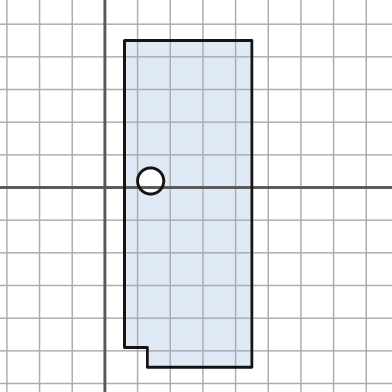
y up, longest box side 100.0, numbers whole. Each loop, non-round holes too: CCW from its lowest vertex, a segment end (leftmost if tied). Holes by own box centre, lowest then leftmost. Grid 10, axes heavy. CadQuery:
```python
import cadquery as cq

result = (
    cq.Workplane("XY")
    .moveTo(13.0, -55.0)
    .lineTo(45.0, -55.0)
    .lineTo(45.0, 45.0)
    .lineTo(6.0, 45.0)
    .lineTo(6.0, -49.0)
    .lineTo(13.0, -49.0)
    .close()
    .moveTo(14.0, 2.0)
    .circle(4.0)
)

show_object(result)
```